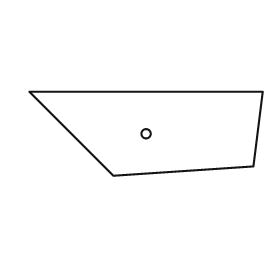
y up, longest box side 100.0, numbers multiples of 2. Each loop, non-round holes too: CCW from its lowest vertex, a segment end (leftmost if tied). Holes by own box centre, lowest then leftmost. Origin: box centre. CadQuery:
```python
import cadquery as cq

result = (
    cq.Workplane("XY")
    .moveTo(-14.0, -18.0)
    .lineTo(46.0, -14.0)
    .lineTo(50.0, 18.0)
    .lineTo(-50.0, 18.0)
    .close()
    .moveTo(0.0, 0.0)
    .circle(2.0)
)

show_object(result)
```